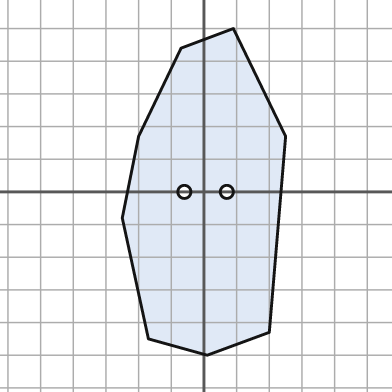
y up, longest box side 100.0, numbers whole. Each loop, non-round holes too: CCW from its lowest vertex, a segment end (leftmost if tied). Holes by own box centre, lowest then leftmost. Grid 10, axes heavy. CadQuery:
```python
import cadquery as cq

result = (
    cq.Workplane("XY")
    .moveTo(1.0, -50.0)
    .lineTo(20.0, -43.0)
    .lineTo(25.0, 17.0)
    .lineTo(9.0, 50.0)
    .lineTo(-7.0, 44.0)
    .lineTo(-20.0, 17.0)
    .lineTo(-25.0, -8.0)
    .lineTo(-17.0, -45.0)
    .close()
    .moveTo(-6.0, 0.0)
    .circle(2.0)
    .moveTo(7.0, 0.0)
    .circle(2.0)
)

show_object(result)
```